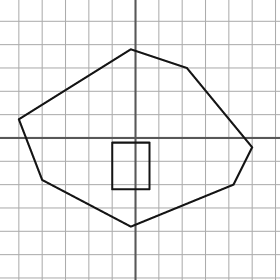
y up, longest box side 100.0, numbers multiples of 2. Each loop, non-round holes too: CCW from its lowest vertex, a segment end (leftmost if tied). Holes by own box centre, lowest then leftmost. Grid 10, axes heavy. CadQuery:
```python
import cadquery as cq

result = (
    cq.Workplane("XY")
    .moveTo(-2.0, -38.0)
    .lineTo(42.0, -20.0)
    .lineTo(50.0, -4.0)
    .lineTo(22.0, 30.0)
    .lineTo(-2.0, 38.0)
    .lineTo(-50.0, 8.0)
    .lineTo(-40.0, -18.0)
    .close()
    .moveTo(-10.0, -22.0)
    .lineTo(6.0, -22.0)
    .lineTo(6.0, -2.0)
    .lineTo(-10.0, -2.0)
    .close()
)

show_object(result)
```